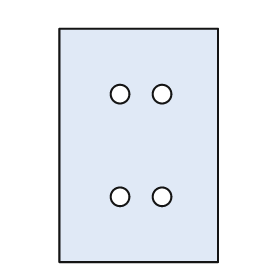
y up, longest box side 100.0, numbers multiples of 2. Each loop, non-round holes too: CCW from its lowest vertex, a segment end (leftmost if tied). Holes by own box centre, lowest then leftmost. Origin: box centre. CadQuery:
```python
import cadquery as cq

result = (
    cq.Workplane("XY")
    .moveTo(-34.0, -50.0)
    .lineTo(34.0, -50.0)
    .lineTo(34.0, 50.0)
    .lineTo(-34.0, 50.0)
    .close()
    .moveTo(-8.0, -22.0)
    .circle(4.0)
    .moveTo(10.0, -22.0)
    .circle(4.0)
    .moveTo(-8.0, 22.0)
    .circle(4.0)
    .moveTo(10.0, 22.0)
    .circle(4.0)
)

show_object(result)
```